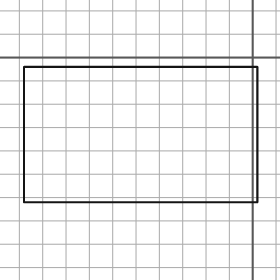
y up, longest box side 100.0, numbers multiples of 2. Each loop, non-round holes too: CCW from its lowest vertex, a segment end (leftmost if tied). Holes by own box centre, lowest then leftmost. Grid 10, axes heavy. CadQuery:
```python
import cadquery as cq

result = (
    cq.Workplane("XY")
    .moveTo(-98.0, -62.0)
    .lineTo(2.0, -62.0)
    .lineTo(2.0, -4.0)
    .lineTo(-98.0, -4.0)
    .close()
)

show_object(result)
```